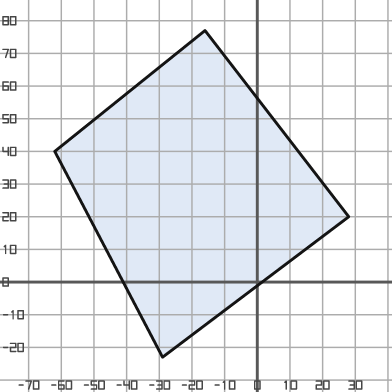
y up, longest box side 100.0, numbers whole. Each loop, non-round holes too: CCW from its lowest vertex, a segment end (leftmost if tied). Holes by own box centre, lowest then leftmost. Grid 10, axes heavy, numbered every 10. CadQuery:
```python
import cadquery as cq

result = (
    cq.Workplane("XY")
    .moveTo(-29.0, -23.0)
    .lineTo(28.0, 20.0)
    .lineTo(-16.0, 77.0)
    .lineTo(-62.0, 40.0)
    .close()
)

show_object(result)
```